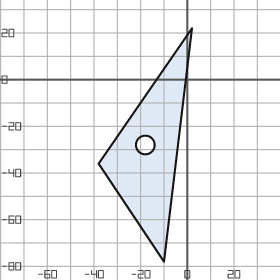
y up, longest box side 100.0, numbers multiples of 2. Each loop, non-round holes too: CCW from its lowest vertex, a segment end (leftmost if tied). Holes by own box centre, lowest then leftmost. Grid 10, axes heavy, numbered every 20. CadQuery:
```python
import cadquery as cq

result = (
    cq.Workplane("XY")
    .moveTo(-10.0, -78.0)
    .lineTo(2.0, 22.0)
    .lineTo(-38.0, -36.0)
    .close()
    .moveTo(-18.0, -28.0)
    .circle(4.0)
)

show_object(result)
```